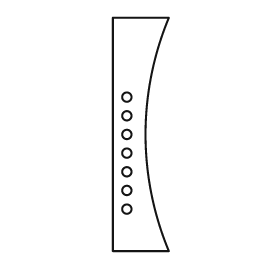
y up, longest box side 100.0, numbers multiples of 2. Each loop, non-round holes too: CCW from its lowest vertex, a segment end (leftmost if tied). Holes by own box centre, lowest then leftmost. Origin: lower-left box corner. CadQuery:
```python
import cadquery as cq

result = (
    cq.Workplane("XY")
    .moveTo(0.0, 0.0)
    .lineTo(24.0, 0.0)
    .threePointArc((14.0, 50.0), (24.0, 100.0))
    .lineTo(0.0, 100.0)
    .close()
    .moveTo(6.0, 18.0)
    .circle(2.0)
    .moveTo(6.0, 26.0)
    .circle(2.0)
    .moveTo(6.0, 34.0)
    .circle(2.0)
    .moveTo(6.0, 42.0)
    .circle(2.0)
    .moveTo(6.0, 50.0)
    .circle(2.0)
    .moveTo(6.0, 58.0)
    .circle(2.0)
    .moveTo(6.0, 66.0)
    .circle(2.0)
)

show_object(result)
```